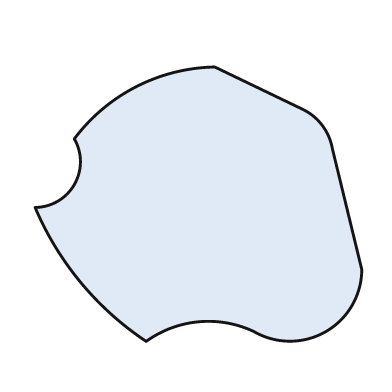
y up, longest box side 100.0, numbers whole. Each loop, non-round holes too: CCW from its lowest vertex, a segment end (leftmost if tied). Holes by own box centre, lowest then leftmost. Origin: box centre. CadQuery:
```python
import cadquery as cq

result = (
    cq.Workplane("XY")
    .moveTo(-16.0, -42.0)
    .threePointArc((0.0, -36.0), (17.0, -39.0))
    .threePointArc((39.0, -39.0), (50.0, -20.0))
    .lineTo(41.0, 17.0)
    .threePointArc((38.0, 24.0), (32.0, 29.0))
    .lineTo(5.0, 42.0)
    .threePointArc((-19.0, 36.0), (-38.0, 20.0))
    .threePointArc((-38.0, 6.0), (-50.0, -1.0))
    .threePointArc((-36.0, -24.0), (-16.0, -42.0))
    .close()
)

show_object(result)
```